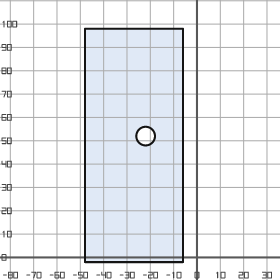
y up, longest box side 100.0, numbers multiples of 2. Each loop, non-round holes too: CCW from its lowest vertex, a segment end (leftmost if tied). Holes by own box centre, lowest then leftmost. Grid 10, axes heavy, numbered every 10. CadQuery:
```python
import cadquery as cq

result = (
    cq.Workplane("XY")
    .moveTo(-48.0, -2.0)
    .lineTo(-6.0, -2.0)
    .lineTo(-6.0, 98.0)
    .lineTo(-48.0, 98.0)
    .close()
    .moveTo(-22.0, 52.0)
    .circle(4.0)
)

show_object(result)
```